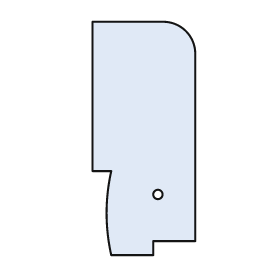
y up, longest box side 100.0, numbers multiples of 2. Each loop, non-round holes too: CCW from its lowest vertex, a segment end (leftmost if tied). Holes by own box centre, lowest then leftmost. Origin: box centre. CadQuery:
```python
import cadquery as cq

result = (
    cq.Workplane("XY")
    .moveTo(-14.0, -50.0)
    .lineTo(4.0, -50.0)
    .lineTo(4.0, -44.0)
    .lineTo(22.0, -44.0)
    .lineTo(22.0, 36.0)
    .threePointArc((18.0, 46.0), (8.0, 50.0))
    .lineTo(-22.0, 50.0)
    .lineTo(-22.0, -14.0)
    .lineTo(-14.0, -14.0)
    .threePointArc((-16.0, -32.0), (-14.0, -50.0))
    .close()
    .moveTo(6.0, -24.0)
    .circle(2.0)
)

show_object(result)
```